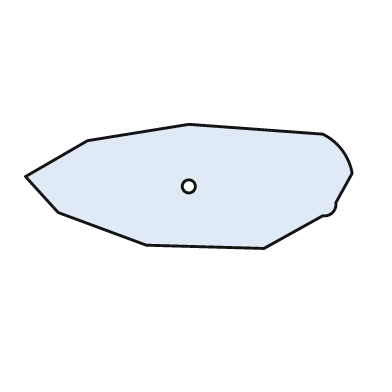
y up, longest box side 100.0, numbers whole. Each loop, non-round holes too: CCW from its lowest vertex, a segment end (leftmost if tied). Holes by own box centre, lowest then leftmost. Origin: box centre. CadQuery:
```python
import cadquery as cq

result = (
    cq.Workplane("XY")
    .moveTo(23.0, -19.0)
    .lineTo(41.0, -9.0)
    .threePointArc((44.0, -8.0), (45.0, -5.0))
    .lineTo(50.0, 4.0)
    .threePointArc((47.0, 11.0), (41.0, 16.0))
    .lineTo(0.0, 19.0)
    .lineTo(-31.0, 14.0)
    .lineTo(-50.0, 3.0)
    .lineTo(-40.0, -8.0)
    .lineTo(-13.0, -18.0)
    .close()
    .moveTo(0.0, 0.0)
    .circle(2.0)
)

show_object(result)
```